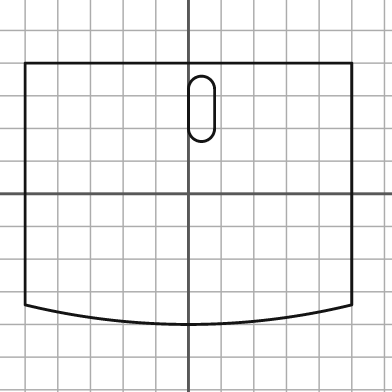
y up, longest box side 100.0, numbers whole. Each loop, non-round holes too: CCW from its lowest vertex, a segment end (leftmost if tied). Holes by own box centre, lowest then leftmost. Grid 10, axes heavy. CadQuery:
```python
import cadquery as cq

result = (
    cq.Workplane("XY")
    .moveTo(-50.0, -34.0)
    .threePointArc((0.0, -40.0), (50.0, -34.0))
    .lineTo(50.0, 40.0)
    .lineTo(-50.0, 40.0)
    .close()
    .moveTo(0.0, 20.0)
    .threePointArc((4.0, 16.0), (8.0, 20.0))
    .lineTo(8.0, 32.0)
    .threePointArc((4.0, 36.0), (0.0, 32.0))
    .close()
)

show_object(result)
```